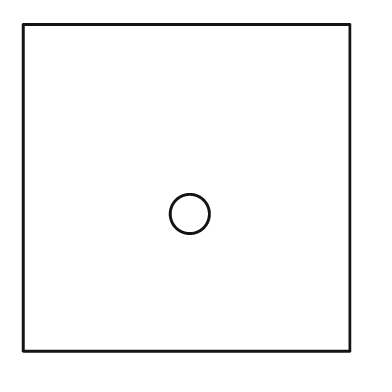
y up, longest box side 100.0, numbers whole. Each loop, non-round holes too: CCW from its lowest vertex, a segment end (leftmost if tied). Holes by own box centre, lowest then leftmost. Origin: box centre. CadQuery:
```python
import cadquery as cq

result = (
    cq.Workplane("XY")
    .moveTo(-50.0, -50.0)
    .lineTo(50.0, -50.0)
    .lineTo(50.0, 50.0)
    .lineTo(-50.0, 50.0)
    .close()
    .moveTo(1.0, -8.0)
    .circle(6.0)
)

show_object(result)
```